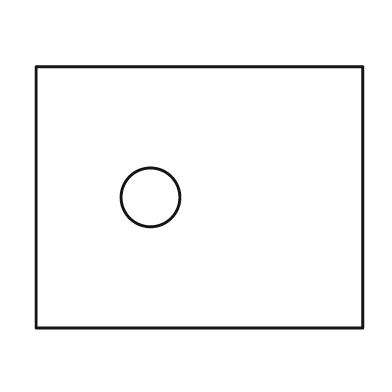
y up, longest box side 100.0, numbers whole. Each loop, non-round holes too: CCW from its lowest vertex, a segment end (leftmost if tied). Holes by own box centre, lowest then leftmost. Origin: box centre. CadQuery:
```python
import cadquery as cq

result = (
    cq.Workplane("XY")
    .moveTo(-50.0, -40.0)
    .lineTo(50.0, -40.0)
    .lineTo(50.0, 40.0)
    .lineTo(-50.0, 40.0)
    .close()
    .moveTo(-15.0, 0.0)
    .circle(9.0)
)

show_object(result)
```